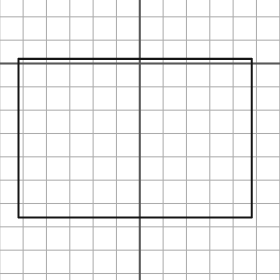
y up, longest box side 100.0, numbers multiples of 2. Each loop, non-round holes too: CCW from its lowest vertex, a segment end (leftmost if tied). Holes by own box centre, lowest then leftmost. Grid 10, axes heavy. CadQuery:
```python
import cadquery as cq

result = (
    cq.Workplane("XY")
    .moveTo(-52.0, -66.0)
    .lineTo(48.0, -66.0)
    .lineTo(48.0, 2.0)
    .lineTo(-52.0, 2.0)
    .close()
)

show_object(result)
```